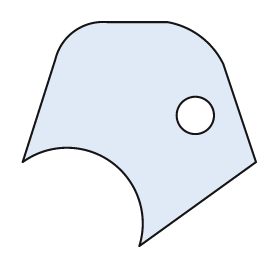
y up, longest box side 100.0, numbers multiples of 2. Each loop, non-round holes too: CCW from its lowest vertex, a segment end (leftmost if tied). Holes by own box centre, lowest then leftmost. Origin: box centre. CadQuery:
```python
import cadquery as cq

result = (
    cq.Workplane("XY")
    .moveTo(0.0, -48.0)
    .lineTo(50.0, -12.0)
    .lineTo(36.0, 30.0)
    .threePointArc((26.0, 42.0), (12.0, 48.0))
    .lineTo(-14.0, 48.0)
    .threePointArc((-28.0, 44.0), (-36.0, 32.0))
    .lineTo(-50.0, -12.0)
    .threePointArc((-12.0, -12.0), (0.0, -48.0))
    .close()
    .moveTo(24.0, 8.0)
    .circle(8.0)
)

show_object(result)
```